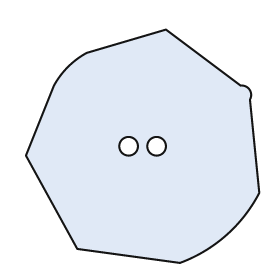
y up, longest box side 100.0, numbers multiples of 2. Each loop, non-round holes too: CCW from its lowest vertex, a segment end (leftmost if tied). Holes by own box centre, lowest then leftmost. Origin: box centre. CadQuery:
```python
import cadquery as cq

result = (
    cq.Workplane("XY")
    .moveTo(16.0, -50.0)
    .threePointArc((36.0, -38.0), (50.0, -20.0))
    .lineTo(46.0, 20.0)
    .threePointArc((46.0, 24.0), (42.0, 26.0))
    .lineTo(10.0, 50.0)
    .lineTo(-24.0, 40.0)
    .threePointArc((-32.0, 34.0), (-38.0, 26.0))
    .lineTo(-50.0, -4.0)
    .lineTo(-28.0, -44.0)
    .close()
    .moveTo(-6.0, 0.0)
    .circle(4.0)
    .moveTo(6.0, 0.0)
    .circle(4.0)
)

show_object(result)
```